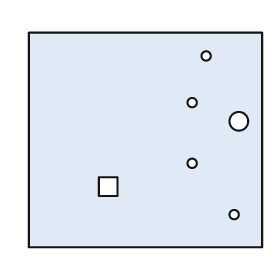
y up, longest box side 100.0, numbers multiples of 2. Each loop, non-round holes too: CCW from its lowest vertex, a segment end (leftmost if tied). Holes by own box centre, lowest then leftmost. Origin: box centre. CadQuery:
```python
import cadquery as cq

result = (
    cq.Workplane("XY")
    .moveTo(-50.0, -46.0)
    .lineTo(50.0, -46.0)
    .lineTo(50.0, 46.0)
    .lineTo(-50.0, 46.0)
    .close()
    .moveTo(38.0, -32.0)
    .circle(2.0)
    .moveTo(-20.0, -24.0)
    .lineTo(-12.0, -24.0)
    .lineTo(-12.0, -16.0)
    .lineTo(-20.0, -16.0)
    .close()
    .moveTo(20.0, -10.0)
    .circle(2.0)
    .moveTo(40.0, 8.0)
    .circle(4.0)
    .moveTo(20.0, 16.0)
    .circle(2.0)
    .moveTo(26.0, 36.0)
    .circle(2.0)
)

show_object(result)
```